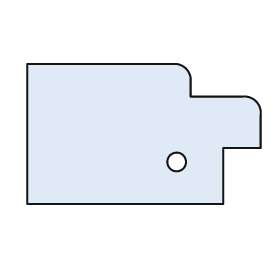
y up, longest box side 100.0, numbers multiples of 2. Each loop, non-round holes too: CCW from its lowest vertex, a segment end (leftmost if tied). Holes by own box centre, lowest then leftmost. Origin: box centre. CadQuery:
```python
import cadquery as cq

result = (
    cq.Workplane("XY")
    .moveTo(-50.0, -30.0)
    .lineTo(34.0, -30.0)
    .lineTo(34.0, -6.0)
    .lineTo(50.0, -6.0)
    .lineTo(50.0, 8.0)
    .threePointArc((48.0, 14.0), (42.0, 16.0))
    .lineTo(20.0, 16.0)
    .lineTo(20.0, 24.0)
    .threePointArc((18.0, 28.0), (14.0, 30.0))
    .lineTo(-50.0, 30.0)
    .close()
    .moveTo(14.0, -12.0)
    .circle(4.0)
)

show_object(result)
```